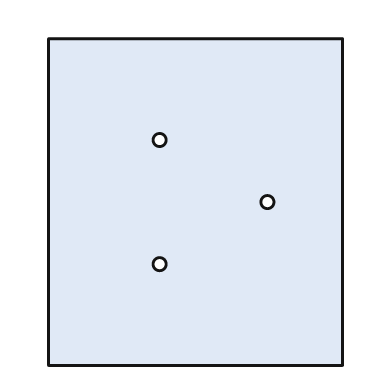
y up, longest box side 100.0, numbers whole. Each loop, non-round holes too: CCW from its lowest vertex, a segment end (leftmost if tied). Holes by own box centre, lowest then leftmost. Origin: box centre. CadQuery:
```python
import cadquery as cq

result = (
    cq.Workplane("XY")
    .moveTo(-45.0, -50.0)
    .lineTo(45.0, -50.0)
    .lineTo(45.0, 50.0)
    .lineTo(-45.0, 50.0)
    .close()
    .moveTo(-11.0, -19.0)
    .circle(2.0)
    .moveTo(22.0, 0.0)
    .circle(2.0)
    .moveTo(-11.0, 19.0)
    .circle(2.0)
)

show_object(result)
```